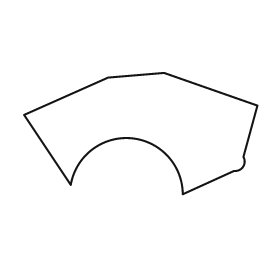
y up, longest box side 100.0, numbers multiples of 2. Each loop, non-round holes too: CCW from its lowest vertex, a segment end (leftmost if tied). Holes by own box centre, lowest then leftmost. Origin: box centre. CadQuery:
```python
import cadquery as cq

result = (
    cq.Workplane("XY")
    .moveTo(18.0, -26.0)
    .lineTo(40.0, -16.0)
    .threePointArc((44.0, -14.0), (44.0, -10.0))
    .lineTo(50.0, 12.0)
    .lineTo(10.0, 26.0)
    .lineTo(-14.0, 24.0)
    .lineTo(-50.0, 8.0)
    .lineTo(-30.0, -22.0)
    .threePointArc((-4.0, -2.0), (18.0, -26.0))
    .close()
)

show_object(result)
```